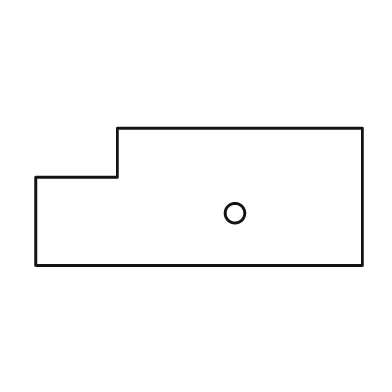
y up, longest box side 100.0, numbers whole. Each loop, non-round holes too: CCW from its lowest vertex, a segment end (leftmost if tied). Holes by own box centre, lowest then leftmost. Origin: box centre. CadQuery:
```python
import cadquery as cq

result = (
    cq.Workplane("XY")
    .moveTo(-50.0, -21.0)
    .lineTo(50.0, -21.0)
    .lineTo(50.0, 21.0)
    .lineTo(-25.0, 21.0)
    .lineTo(-25.0, 6.0)
    .lineTo(-50.0, 6.0)
    .close()
    .moveTo(11.0, -5.0)
    .circle(3.0)
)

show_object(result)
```